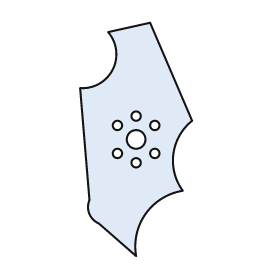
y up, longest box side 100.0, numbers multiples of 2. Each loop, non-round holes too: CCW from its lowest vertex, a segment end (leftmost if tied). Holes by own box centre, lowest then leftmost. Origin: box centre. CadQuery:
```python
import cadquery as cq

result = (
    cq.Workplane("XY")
    .moveTo(0.0, -50.0)
    .threePointArc((4.0, -32.0), (20.0, -22.0))
    .threePointArc((16.0, -6.0), (24.0, 8.0))
    .lineTo(6.0, 50.0)
    .lineTo(-12.0, 46.0)
    .threePointArc((-10.0, 30.0), (-24.0, 22.0))
    .lineTo(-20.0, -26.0)
    .threePointArc((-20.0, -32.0), (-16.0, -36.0))
    .close()
    .moveTo(0.0, -10.0)
    .circle(2.0)
    .moveTo(-8.0, -6.0)
    .circle(2.0)
    .moveTo(8.0, -6.0)
    .circle(2.0)
    .moveTo(0.0, 0.0)
    .circle(4.0)
    .moveTo(-8.0, 6.0)
    .circle(2.0)
    .moveTo(8.0, 6.0)
    .circle(2.0)
    .moveTo(0.0, 10.0)
    .circle(2.0)
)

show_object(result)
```